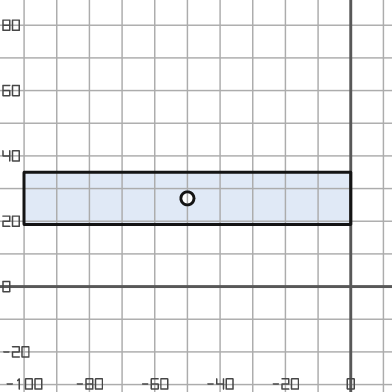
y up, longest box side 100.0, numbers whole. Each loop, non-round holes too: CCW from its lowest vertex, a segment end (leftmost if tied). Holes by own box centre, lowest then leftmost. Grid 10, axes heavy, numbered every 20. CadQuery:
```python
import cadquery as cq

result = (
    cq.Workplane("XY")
    .moveTo(-100.0, 19.0)
    .lineTo(0.0, 19.0)
    .lineTo(0.0, 35.0)
    .lineTo(-100.0, 35.0)
    .close()
    .moveTo(-50.0, 27.0)
    .circle(2.0)
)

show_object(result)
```